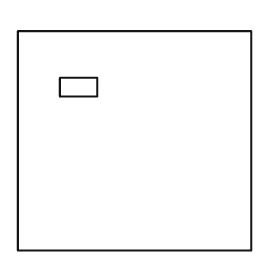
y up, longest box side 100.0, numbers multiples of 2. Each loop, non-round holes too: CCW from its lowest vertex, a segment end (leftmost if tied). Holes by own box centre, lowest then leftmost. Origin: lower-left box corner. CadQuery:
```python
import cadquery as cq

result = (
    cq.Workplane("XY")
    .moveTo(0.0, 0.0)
    .lineTo(100.0, 0.0)
    .lineTo(100.0, 94.0)
    .lineTo(0.0, 94.0)
    .close()
    .moveTo(18.0, 66.0)
    .lineTo(34.0, 66.0)
    .lineTo(34.0, 74.0)
    .lineTo(18.0, 74.0)
    .close()
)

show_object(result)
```